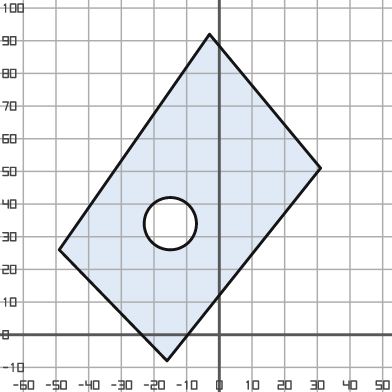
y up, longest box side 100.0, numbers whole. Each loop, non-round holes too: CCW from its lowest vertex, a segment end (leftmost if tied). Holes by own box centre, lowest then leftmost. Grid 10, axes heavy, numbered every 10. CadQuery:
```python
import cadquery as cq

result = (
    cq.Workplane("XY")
    .moveTo(-16.0, -8.0)
    .lineTo(31.0, 51.0)
    .lineTo(-3.0, 92.0)
    .lineTo(-49.0, 26.0)
    .close()
    .moveTo(-15.0, 34.0)
    .circle(8.0)
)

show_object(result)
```